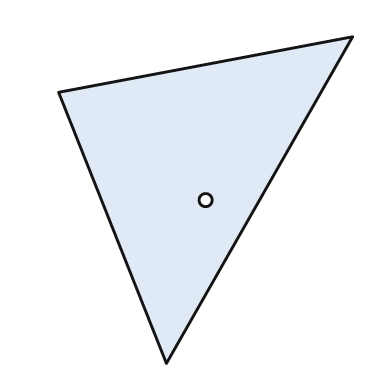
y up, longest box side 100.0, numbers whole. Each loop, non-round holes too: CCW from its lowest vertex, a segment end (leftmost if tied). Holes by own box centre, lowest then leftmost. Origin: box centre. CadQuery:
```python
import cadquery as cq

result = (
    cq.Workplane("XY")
    .moveTo(-12.0, -50.0)
    .lineTo(45.0, 50.0)
    .lineTo(-45.0, 33.0)
    .close()
    .moveTo(0.0, 0.0)
    .circle(2.0)
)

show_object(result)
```